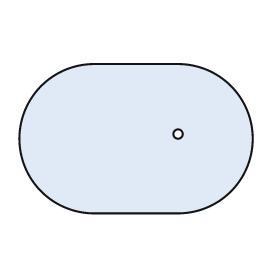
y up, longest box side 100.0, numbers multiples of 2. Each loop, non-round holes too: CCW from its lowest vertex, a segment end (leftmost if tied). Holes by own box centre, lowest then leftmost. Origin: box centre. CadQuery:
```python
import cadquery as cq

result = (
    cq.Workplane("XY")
    .moveTo(-18.0, -32.0)
    .lineTo(18.0, -32.0)
    .threePointArc((50.0, 0.0), (18.0, 32.0))
    .lineTo(-18.0, 32.0)
    .threePointArc((-50.0, 0.0), (-18.0, -32.0))
    .close()
    .moveTo(18.0, 2.0)
    .circle(2.0)
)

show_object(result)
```